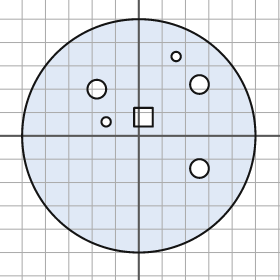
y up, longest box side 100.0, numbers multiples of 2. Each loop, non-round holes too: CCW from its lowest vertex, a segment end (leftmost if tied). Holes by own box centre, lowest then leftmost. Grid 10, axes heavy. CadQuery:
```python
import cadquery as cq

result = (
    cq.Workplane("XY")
    .moveTo(0.0, 0.0)
    .circle(50.0)
    .moveTo(26.0, -14.0)
    .circle(4.0)
    .moveTo(-14.0, 6.0)
    .circle(2.0)
    .moveTo(-2.0, 4.0)
    .lineTo(6.0, 4.0)
    .lineTo(6.0, 12.0)
    .lineTo(-2.0, 12.0)
    .close()
    .moveTo(-18.0, 20.0)
    .circle(4.0)
    .moveTo(26.0, 22.0)
    .circle(4.0)
    .moveTo(16.0, 34.0)
    .circle(2.0)
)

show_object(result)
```